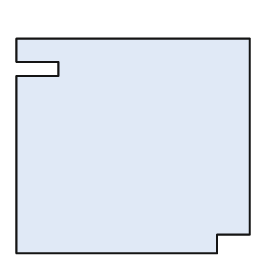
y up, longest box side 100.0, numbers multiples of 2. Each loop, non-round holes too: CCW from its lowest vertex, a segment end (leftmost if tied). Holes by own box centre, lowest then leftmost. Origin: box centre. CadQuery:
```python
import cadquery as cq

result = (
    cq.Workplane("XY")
    .moveTo(-50.0, -46.0)
    .lineTo(36.0, -46.0)
    .lineTo(36.0, -38.0)
    .lineTo(50.0, -38.0)
    .lineTo(50.0, 46.0)
    .lineTo(-50.0, 46.0)
    .lineTo(-50.0, 36.0)
    .lineTo(-32.0, 36.0)
    .lineTo(-32.0, 30.0)
    .lineTo(-50.0, 30.0)
    .close()
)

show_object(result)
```